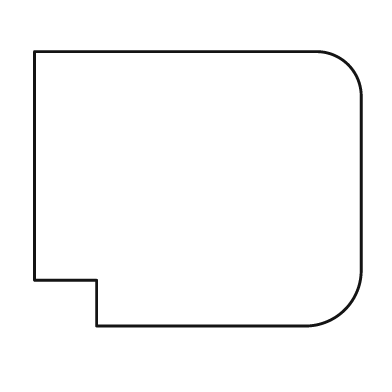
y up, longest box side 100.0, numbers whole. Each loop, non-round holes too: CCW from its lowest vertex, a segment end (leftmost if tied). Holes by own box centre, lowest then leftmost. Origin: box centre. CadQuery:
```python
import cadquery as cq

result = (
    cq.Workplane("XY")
    .moveTo(-31.0, -42.0)
    .lineTo(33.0, -42.0)
    .threePointArc((45.0, -37.0), (50.0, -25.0))
    .lineTo(50.0, 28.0)
    .threePointArc((46.0, 38.0), (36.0, 42.0))
    .lineTo(-50.0, 42.0)
    .lineTo(-50.0, -28.0)
    .lineTo(-31.0, -28.0)
    .close()
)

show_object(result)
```